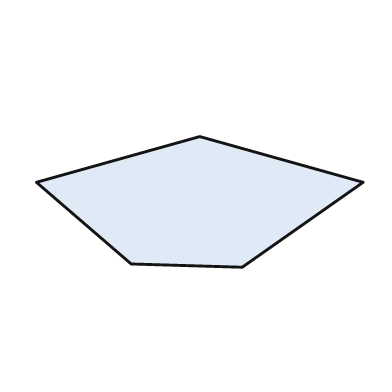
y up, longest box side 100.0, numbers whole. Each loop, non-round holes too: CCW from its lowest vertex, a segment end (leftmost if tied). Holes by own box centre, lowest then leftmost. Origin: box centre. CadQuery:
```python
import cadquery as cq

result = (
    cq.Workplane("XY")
    .moveTo(13.0, -20.0)
    .lineTo(50.0, 6.0)
    .lineTo(0.0, 20.0)
    .lineTo(-50.0, 6.0)
    .lineTo(-21.0, -19.0)
    .close()
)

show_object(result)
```